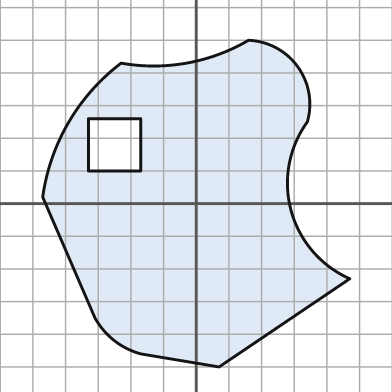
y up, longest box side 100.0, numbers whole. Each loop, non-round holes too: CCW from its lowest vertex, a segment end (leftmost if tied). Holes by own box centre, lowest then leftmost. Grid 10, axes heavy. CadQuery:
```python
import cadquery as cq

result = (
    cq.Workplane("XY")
    .moveTo(7.0, -50.0)
    .lineTo(47.0, -23.0)
    .threePointArc((29.0, -2.0), (34.0, 25.0))
    .threePointArc((31.0, 42.0), (16.0, 50.0))
    .threePointArc((-3.0, 43.0), (-23.0, 43.0))
    .threePointArc((-39.0, 25.0), (-47.0, 2.0))
    .lineTo(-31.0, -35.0)
    .threePointArc((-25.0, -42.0), (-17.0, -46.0))
    .close()
    .moveTo(-33.0, 10.0)
    .lineTo(-17.0, 10.0)
    .lineTo(-17.0, 26.0)
    .lineTo(-33.0, 26.0)
    .close()
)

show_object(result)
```